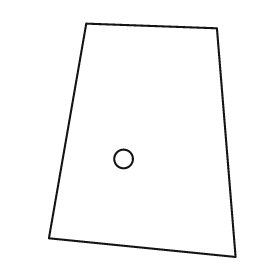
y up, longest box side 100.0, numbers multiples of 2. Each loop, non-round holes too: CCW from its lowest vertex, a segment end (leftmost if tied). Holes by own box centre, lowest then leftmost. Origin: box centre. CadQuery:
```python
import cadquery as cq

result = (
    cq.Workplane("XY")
    .moveTo(40.0, -50.0)
    .lineTo(32.0, 48.0)
    .lineTo(-24.0, 50.0)
    .lineTo(-40.0, -42.0)
    .close()
    .moveTo(-8.0, -8.0)
    .circle(4.0)
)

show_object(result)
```